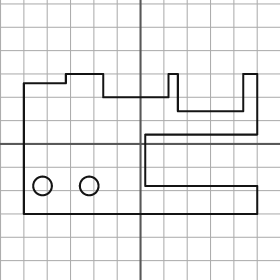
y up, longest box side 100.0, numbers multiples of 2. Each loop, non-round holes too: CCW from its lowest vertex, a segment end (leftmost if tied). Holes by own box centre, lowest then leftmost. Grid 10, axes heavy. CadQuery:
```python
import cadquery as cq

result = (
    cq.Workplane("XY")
    .moveTo(-50.0, -30.0)
    .lineTo(50.0, -30.0)
    .lineTo(50.0, -18.0)
    .lineTo(2.0, -18.0)
    .lineTo(2.0, 4.0)
    .lineTo(50.0, 4.0)
    .lineTo(50.0, 30.0)
    .lineTo(44.0, 30.0)
    .lineTo(44.0, 14.0)
    .lineTo(16.0, 14.0)
    .lineTo(16.0, 30.0)
    .lineTo(12.0, 30.0)
    .lineTo(12.0, 20.0)
    .lineTo(-16.0, 20.0)
    .lineTo(-16.0, 30.0)
    .lineTo(-32.0, 30.0)
    .lineTo(-32.0, 26.0)
    .lineTo(-50.0, 26.0)
    .close()
    .moveTo(-42.0, -18.0)
    .circle(4.0)
    .moveTo(-22.0, -18.0)
    .circle(4.0)
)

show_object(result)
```